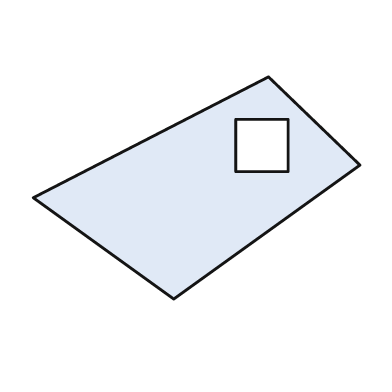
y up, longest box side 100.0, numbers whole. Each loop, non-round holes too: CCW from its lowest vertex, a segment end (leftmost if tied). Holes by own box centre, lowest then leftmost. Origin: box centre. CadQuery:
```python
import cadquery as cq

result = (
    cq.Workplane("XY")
    .moveTo(-7.0, -34.0)
    .lineTo(50.0, 7.0)
    .lineTo(22.0, 34.0)
    .lineTo(-50.0, -3.0)
    .close()
    .moveTo(12.0, 5.0)
    .lineTo(28.0, 5.0)
    .lineTo(28.0, 21.0)
    .lineTo(12.0, 21.0)
    .close()
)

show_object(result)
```